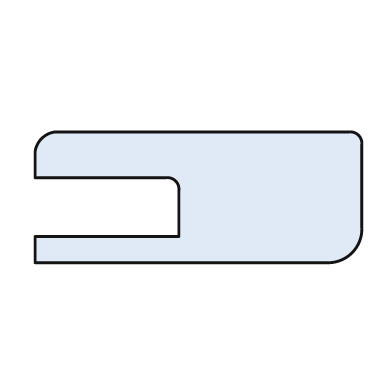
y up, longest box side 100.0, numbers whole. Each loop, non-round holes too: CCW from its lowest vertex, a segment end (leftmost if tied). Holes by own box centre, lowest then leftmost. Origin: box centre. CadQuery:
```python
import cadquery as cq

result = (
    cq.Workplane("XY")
    .moveTo(-50.0, -20.0)
    .lineTo(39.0, -20.0)
    .threePointArc((47.0, -17.0), (50.0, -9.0))
    .lineTo(50.0, 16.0)
    .threePointArc((49.0, 19.0), (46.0, 20.0))
    .lineTo(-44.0, 20.0)
    .threePointArc((-48.0, 18.0), (-50.0, 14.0))
    .lineTo(-50.0, 6.0)
    .lineTo(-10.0, 6.0)
    .threePointArc((-7.0, 5.0), (-6.0, 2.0))
    .lineTo(-6.0, -12.0)
    .lineTo(-50.0, -12.0)
    .close()
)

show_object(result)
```